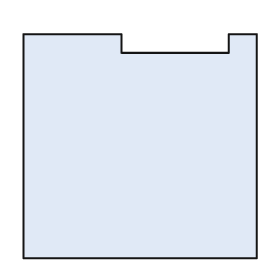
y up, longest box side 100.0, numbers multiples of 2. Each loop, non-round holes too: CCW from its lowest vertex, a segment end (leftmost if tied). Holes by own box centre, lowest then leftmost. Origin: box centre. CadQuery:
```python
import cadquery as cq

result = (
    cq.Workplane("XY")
    .moveTo(-50.0, -48.0)
    .lineTo(50.0, -48.0)
    .lineTo(50.0, 48.0)
    .lineTo(38.0, 48.0)
    .lineTo(38.0, 40.0)
    .lineTo(-8.0, 40.0)
    .lineTo(-8.0, 48.0)
    .lineTo(-50.0, 48.0)
    .close()
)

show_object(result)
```